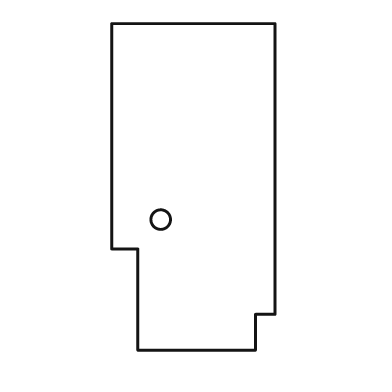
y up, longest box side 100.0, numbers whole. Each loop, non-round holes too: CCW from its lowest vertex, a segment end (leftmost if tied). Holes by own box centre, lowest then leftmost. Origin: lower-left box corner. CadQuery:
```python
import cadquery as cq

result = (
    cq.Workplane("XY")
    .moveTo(8.0, 0.0)
    .lineTo(44.0, 0.0)
    .lineTo(44.0, 11.0)
    .lineTo(50.0, 11.0)
    .lineTo(50.0, 100.0)
    .lineTo(0.0, 100.0)
    .lineTo(0.0, 31.0)
    .lineTo(8.0, 31.0)
    .close()
    .moveTo(15.0, 40.0)
    .circle(3.0)
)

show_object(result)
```